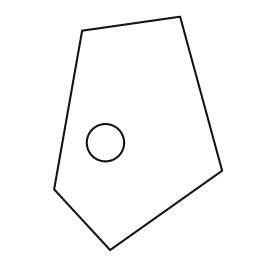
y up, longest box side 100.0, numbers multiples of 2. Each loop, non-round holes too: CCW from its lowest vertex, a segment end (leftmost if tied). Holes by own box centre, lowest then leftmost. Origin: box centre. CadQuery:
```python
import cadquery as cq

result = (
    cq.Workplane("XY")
    .moveTo(-12.0, -50.0)
    .lineTo(36.0, -16.0)
    .lineTo(18.0, 50.0)
    .lineTo(-24.0, 44.0)
    .lineTo(-36.0, -24.0)
    .close()
    .moveTo(-14.0, -4.0)
    .circle(8.0)
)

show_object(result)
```